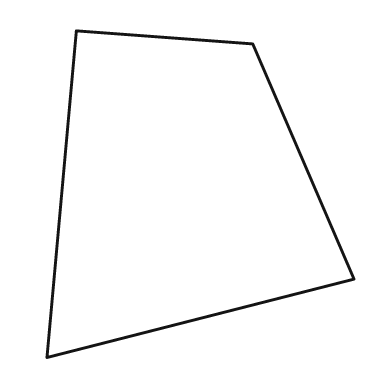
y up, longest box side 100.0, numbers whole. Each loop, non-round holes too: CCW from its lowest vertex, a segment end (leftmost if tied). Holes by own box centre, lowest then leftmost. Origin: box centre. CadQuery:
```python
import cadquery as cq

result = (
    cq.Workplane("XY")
    .moveTo(-47.0, -50.0)
    .lineTo(47.0, -26.0)
    .lineTo(16.0, 46.0)
    .lineTo(-38.0, 50.0)
    .close()
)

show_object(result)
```